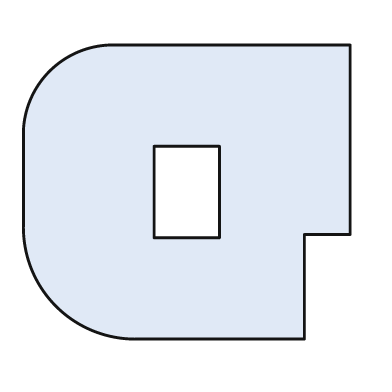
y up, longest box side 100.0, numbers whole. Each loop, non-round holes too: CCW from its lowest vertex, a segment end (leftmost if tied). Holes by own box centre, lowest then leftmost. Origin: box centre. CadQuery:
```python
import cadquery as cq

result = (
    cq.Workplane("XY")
    .moveTo(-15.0, -45.0)
    .lineTo(36.0, -45.0)
    .lineTo(36.0, -13.0)
    .lineTo(50.0, -13.0)
    .lineTo(50.0, 45.0)
    .lineTo(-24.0, 45.0)
    .threePointArc((-42.0, 37.0), (-50.0, 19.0))
    .lineTo(-50.0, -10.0)
    .threePointArc((-40.0, -35.0), (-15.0, -45.0))
    .close()
    .moveTo(-10.0, -14.0)
    .lineTo(10.0, -14.0)
    .lineTo(10.0, 14.0)
    .lineTo(-10.0, 14.0)
    .close()
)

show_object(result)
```